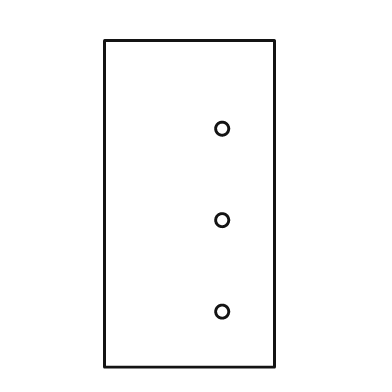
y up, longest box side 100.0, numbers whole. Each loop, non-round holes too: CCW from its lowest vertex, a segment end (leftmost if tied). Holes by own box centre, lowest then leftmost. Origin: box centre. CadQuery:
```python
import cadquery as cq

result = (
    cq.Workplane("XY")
    .moveTo(-26.0, -50.0)
    .lineTo(26.0, -50.0)
    .lineTo(26.0, 50.0)
    .lineTo(-26.0, 50.0)
    .close()
    .moveTo(10.0, -33.0)
    .circle(2.0)
    .moveTo(10.0, -5.0)
    .circle(2.0)
    .moveTo(10.0, 23.0)
    .circle(2.0)
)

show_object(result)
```